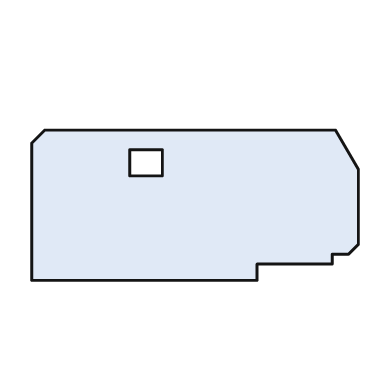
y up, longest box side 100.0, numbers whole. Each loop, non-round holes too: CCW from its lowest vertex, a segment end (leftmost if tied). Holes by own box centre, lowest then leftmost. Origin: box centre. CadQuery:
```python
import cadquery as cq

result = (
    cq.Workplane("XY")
    .moveTo(-50.0, -23.0)
    .lineTo(19.0, -23.0)
    .lineTo(19.0, -18.0)
    .lineTo(42.0, -18.0)
    .lineTo(42.0, -15.0)
    .lineTo(47.0, -15.0)
    .lineTo(50.0, -12.0)
    .lineTo(50.0, 11.0)
    .lineTo(43.0, 23.0)
    .lineTo(-46.0, 23.0)
    .lineTo(-50.0, 19.0)
    .close()
    .moveTo(-20.0, 9.0)
    .lineTo(-10.0, 9.0)
    .lineTo(-10.0, 17.0)
    .lineTo(-20.0, 17.0)
    .close()
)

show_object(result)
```